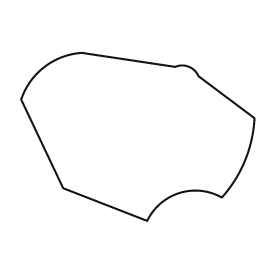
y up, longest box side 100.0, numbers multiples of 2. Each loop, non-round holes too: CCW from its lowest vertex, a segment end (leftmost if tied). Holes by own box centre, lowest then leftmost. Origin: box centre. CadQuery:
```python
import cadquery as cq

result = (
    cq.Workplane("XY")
    .moveTo(4.0, -36.0)
    .threePointArc((18.0, -24.0), (36.0, -26.0))
    .threePointArc((46.0, -10.0), (50.0, 8.0))
    .lineTo(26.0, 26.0)
    .threePointArc((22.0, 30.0), (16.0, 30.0))
    .lineTo(-24.0, 36.0)
    .threePointArc((-40.0, 30.0), (-50.0, 16.0))
    .lineTo(-32.0, -22.0)
    .close()
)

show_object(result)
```